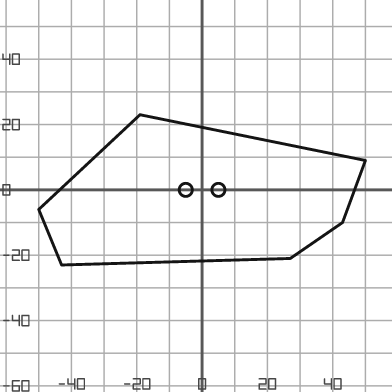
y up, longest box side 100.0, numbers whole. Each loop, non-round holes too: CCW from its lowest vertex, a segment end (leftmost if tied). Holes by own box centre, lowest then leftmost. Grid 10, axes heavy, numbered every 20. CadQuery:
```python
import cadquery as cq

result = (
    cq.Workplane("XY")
    .moveTo(-43.0, -23.0)
    .lineTo(27.0, -21.0)
    .lineTo(43.0, -10.0)
    .lineTo(50.0, 9.0)
    .lineTo(-19.0, 23.0)
    .lineTo(-50.0, -6.0)
    .close()
    .moveTo(-5.0, 0.0)
    .circle(2.0)
    .moveTo(5.0, 0.0)
    .circle(2.0)
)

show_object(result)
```